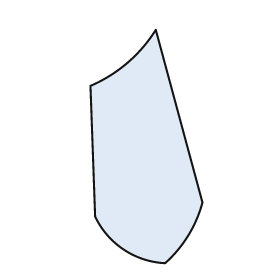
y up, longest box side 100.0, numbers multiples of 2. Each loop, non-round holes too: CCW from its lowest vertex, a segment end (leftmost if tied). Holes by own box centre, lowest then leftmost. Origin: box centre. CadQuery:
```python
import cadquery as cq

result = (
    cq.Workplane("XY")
    .moveTo(8.0, -50.0)
    .threePointArc((18.0, -38.0), (24.0, -24.0))
    .lineTo(4.0, 50.0)
    .threePointArc((-8.0, 36.0), (-24.0, 26.0))
    .lineTo(-22.0, -30.0)
    .threePointArc((-10.0, -44.0), (8.0, -50.0))
    .close()
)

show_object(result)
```